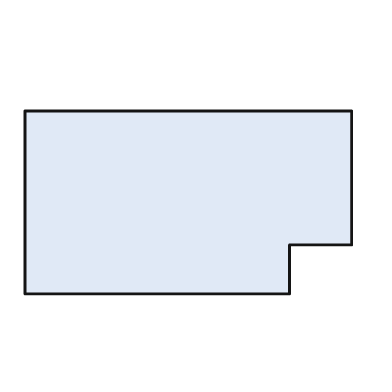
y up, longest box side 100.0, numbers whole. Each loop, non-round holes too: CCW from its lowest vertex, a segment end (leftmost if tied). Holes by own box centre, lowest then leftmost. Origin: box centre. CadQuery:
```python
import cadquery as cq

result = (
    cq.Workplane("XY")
    .moveTo(-50.0, -28.0)
    .lineTo(31.0, -28.0)
    .lineTo(31.0, -13.0)
    .lineTo(50.0, -13.0)
    .lineTo(50.0, 28.0)
    .lineTo(-50.0, 28.0)
    .close()
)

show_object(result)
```